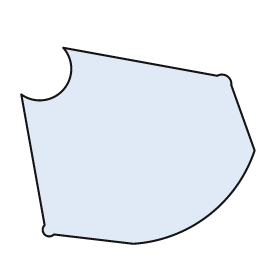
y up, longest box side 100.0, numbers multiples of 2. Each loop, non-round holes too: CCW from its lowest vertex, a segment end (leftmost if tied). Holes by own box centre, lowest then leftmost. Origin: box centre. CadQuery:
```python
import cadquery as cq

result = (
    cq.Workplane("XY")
    .moveTo(-2.0, -42.0)
    .threePointArc((30.0, -30.0), (50.0, -2.0))
    .lineTo(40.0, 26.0)
    .threePointArc((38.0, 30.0), (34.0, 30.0))
    .lineTo(-32.0, 42.0)
    .threePointArc((-32.0, 24.0), (-50.0, 22.0))
    .lineTo(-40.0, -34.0)
    .threePointArc((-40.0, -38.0), (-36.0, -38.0))
    .close()
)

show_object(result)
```